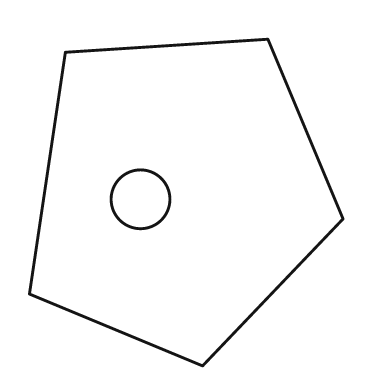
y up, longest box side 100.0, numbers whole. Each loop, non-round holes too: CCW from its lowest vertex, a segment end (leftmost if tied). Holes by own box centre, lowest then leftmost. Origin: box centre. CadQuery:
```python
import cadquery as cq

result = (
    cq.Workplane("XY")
    .moveTo(5.0, -50.0)
    .lineTo(48.0, -5.0)
    .lineTo(25.0, 50.0)
    .lineTo(-37.0, 46.0)
    .lineTo(-48.0, -28.0)
    .close()
    .moveTo(-14.0, 1.0)
    .circle(9.0)
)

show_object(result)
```